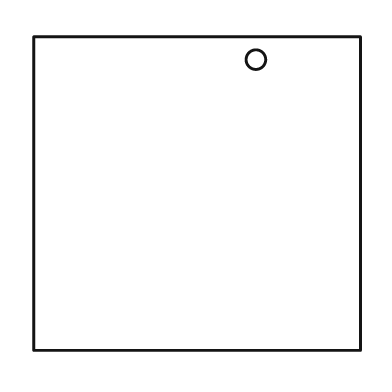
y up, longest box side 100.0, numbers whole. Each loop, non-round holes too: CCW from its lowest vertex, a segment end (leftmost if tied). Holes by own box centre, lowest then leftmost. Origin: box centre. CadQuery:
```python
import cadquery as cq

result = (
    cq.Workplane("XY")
    .moveTo(-50.0, -48.0)
    .lineTo(50.0, -48.0)
    .lineTo(50.0, 48.0)
    .lineTo(-50.0, 48.0)
    .close()
    .moveTo(18.0, 41.0)
    .circle(3.0)
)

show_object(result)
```